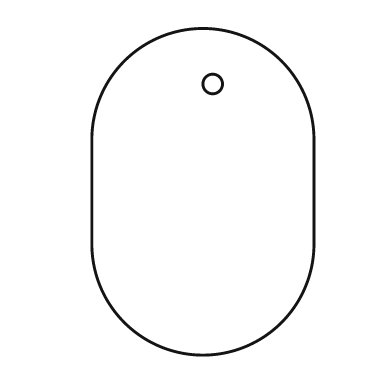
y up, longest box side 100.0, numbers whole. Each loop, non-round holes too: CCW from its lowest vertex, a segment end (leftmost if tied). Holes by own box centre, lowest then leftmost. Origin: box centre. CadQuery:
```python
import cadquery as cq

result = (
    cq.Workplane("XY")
    .moveTo(-34.0, -16.0)
    .threePointArc((0.0, -50.0), (34.0, -16.0))
    .lineTo(34.0, 16.0)
    .threePointArc((0.0, 50.0), (-34.0, 16.0))
    .close()
    .moveTo(3.0, 33.0)
    .circle(3.0)
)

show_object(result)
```